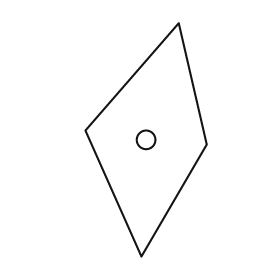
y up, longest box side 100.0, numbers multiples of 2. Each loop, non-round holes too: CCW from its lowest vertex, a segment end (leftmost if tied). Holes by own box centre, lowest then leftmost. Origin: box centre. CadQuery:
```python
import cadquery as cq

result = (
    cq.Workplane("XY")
    .moveTo(-2.0, -50.0)
    .lineTo(26.0, -2.0)
    .lineTo(14.0, 50.0)
    .lineTo(-26.0, 4.0)
    .close()
    .moveTo(0.0, 0.0)
    .circle(4.0)
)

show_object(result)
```